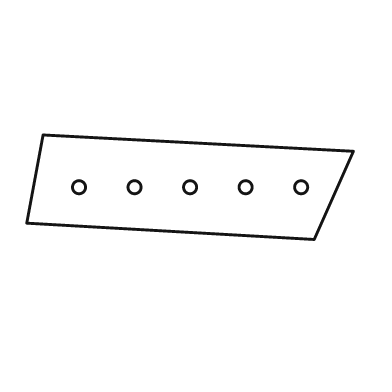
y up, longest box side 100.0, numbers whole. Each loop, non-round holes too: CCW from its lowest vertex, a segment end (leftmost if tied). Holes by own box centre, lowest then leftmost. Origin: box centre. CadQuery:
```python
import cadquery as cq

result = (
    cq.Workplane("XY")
    .moveTo(38.0, -16.0)
    .lineTo(50.0, 11.0)
    .lineTo(-45.0, 16.0)
    .lineTo(-50.0, -11.0)
    .close()
    .moveTo(-34.0, 0.0)
    .circle(2.0)
    .moveTo(-17.0, 0.0)
    .circle(2.0)
    .moveTo(0.0, 0.0)
    .circle(2.0)
    .moveTo(17.0, 0.0)
    .circle(2.0)
    .moveTo(34.0, 0.0)
    .circle(2.0)
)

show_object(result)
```